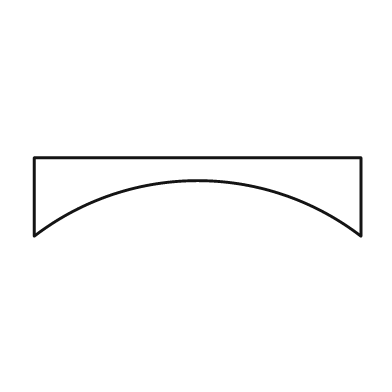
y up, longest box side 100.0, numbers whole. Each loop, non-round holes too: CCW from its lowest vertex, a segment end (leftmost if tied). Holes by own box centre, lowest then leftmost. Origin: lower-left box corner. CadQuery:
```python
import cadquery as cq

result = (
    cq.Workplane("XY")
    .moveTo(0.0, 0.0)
    .threePointArc((50.0, 17.0), (100.0, 0.0))
    .lineTo(100.0, 24.0)
    .lineTo(0.0, 24.0)
    .close()
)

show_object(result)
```